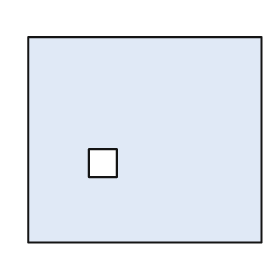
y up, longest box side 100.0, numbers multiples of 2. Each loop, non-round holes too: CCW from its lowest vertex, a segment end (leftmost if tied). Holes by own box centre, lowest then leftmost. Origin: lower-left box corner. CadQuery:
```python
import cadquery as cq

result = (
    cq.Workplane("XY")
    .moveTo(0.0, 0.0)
    .lineTo(100.0, 0.0)
    .lineTo(100.0, 88.0)
    .lineTo(0.0, 88.0)
    .close()
    .moveTo(26.0, 28.0)
    .lineTo(38.0, 28.0)
    .lineTo(38.0, 40.0)
    .lineTo(26.0, 40.0)
    .close()
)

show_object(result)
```